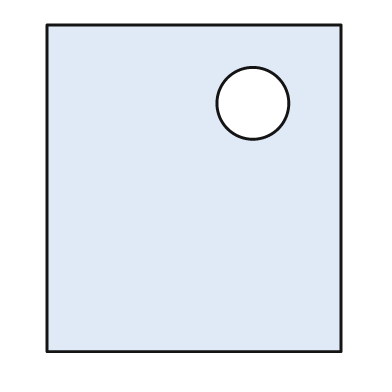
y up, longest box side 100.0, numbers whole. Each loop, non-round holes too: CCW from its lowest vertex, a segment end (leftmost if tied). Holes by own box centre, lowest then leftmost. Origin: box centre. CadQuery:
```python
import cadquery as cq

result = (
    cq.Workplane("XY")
    .moveTo(-45.0, -50.0)
    .lineTo(45.0, -50.0)
    .lineTo(45.0, 50.0)
    .lineTo(-45.0, 50.0)
    .close()
    .moveTo(18.0, 26.0)
    .circle(11.0)
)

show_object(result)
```